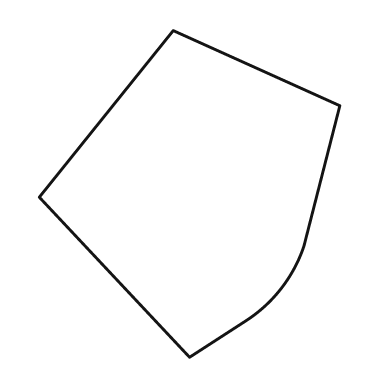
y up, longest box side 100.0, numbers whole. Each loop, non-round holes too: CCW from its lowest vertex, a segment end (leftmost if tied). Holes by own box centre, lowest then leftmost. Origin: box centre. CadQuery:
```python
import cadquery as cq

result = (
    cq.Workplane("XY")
    .moveTo(0.0, -50.0)
    .lineTo(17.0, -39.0)
    .threePointArc((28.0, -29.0), (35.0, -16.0))
    .lineTo(46.0, 27.0)
    .lineTo(-5.0, 50.0)
    .lineTo(-46.0, -1.0)
    .close()
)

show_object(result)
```